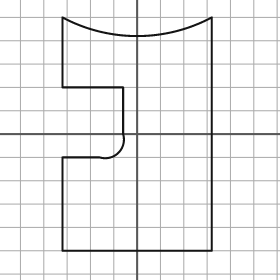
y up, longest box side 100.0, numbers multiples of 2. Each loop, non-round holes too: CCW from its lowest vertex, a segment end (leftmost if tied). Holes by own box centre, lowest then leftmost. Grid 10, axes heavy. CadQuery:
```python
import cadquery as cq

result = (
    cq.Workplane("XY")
    .moveTo(-32.0, -50.0)
    .lineTo(32.0, -50.0)
    .lineTo(32.0, 50.0)
    .threePointArc((0.0, 42.0), (-32.0, 50.0))
    .lineTo(-32.0, 20.0)
    .lineTo(-6.0, 20.0)
    .lineTo(-6.0, 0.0)
    .threePointArc((-8.0, -8.0), (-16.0, -10.0))
    .lineTo(-32.0, -10.0)
    .close()
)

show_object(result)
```